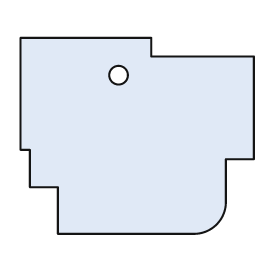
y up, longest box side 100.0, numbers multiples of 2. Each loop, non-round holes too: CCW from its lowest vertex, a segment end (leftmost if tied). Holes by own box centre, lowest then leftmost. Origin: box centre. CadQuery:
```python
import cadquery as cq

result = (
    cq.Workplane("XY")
    .moveTo(-34.0, -42.0)
    .lineTo(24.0, -42.0)
    .threePointArc((34.0, -38.0), (38.0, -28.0))
    .lineTo(38.0, -10.0)
    .lineTo(50.0, -10.0)
    .lineTo(50.0, 34.0)
    .lineTo(6.0, 34.0)
    .lineTo(6.0, 42.0)
    .lineTo(-50.0, 42.0)
    .lineTo(-50.0, -6.0)
    .lineTo(-46.0, -6.0)
    .lineTo(-46.0, -22.0)
    .lineTo(-34.0, -22.0)
    .close()
    .moveTo(-8.0, 26.0)
    .circle(4.0)
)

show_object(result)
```